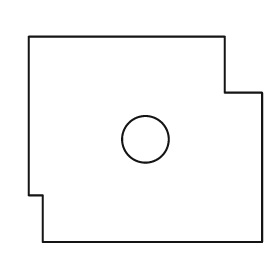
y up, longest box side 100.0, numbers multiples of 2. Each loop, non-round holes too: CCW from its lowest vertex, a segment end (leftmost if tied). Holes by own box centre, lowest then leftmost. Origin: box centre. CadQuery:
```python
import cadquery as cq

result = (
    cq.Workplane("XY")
    .moveTo(-44.0, -44.0)
    .lineTo(50.0, -44.0)
    .lineTo(50.0, 20.0)
    .lineTo(34.0, 20.0)
    .lineTo(34.0, 44.0)
    .lineTo(-50.0, 44.0)
    .lineTo(-50.0, -24.0)
    .lineTo(-44.0, -24.0)
    .close()
    .moveTo(0.0, 0.0)
    .circle(10.0)
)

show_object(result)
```